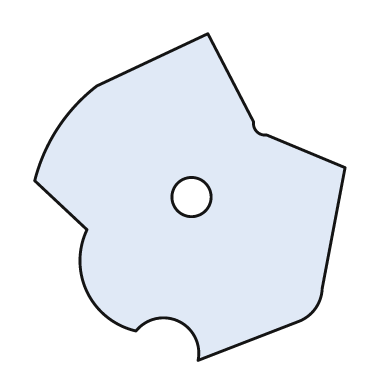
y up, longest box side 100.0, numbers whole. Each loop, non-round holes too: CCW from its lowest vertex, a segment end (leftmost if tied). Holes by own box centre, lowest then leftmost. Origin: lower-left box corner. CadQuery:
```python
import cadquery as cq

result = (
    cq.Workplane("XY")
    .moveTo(50.0, 0.0)
    .lineTo(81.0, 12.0)
    .threePointArc((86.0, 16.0), (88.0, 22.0))
    .lineTo(95.0, 59.0)
    .lineTo(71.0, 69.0)
    .threePointArc((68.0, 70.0), (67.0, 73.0))
    .lineTo(53.0, 100.0)
    .lineTo(19.0, 84.0)
    .threePointArc((7.0, 71.0), (0.0, 55.0))
    .lineTo(16.0, 40.0)
    .threePointArc((16.0, 21.0), (31.0, 9.0))
    .threePointArc((44.0, 12.0), (50.0, 0.0))
    .close()
    .moveTo(48.0, 50.0)
    .circle(6.0)
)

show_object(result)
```